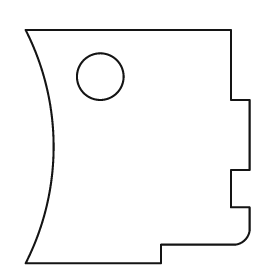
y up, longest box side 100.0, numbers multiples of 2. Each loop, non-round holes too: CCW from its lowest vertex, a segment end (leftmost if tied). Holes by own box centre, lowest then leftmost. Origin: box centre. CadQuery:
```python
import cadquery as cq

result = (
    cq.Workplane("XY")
    .moveTo(-48.0, -50.0)
    .lineTo(10.0, -50.0)
    .lineTo(10.0, -42.0)
    .lineTo(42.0, -42.0)
    .threePointArc((46.0, -40.0), (48.0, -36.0))
    .lineTo(48.0, -26.0)
    .lineTo(40.0, -26.0)
    .lineTo(40.0, -10.0)
    .lineTo(48.0, -10.0)
    .lineTo(48.0, 20.0)
    .lineTo(40.0, 20.0)
    .lineTo(40.0, 50.0)
    .lineTo(-48.0, 50.0)
    .threePointArc((-36.0, 0.0), (-48.0, -50.0))
    .close()
    .moveTo(-16.0, 30.0)
    .circle(10.0)
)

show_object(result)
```